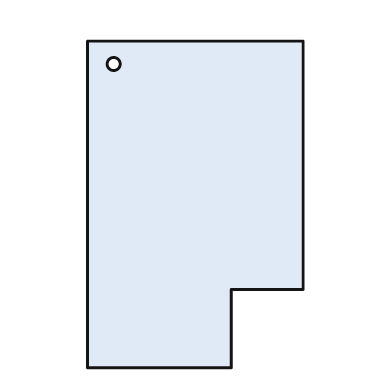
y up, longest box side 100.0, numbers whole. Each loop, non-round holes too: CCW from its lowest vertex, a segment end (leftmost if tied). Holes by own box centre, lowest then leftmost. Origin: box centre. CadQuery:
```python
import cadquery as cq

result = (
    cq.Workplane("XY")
    .moveTo(-33.0, -50.0)
    .lineTo(11.0, -50.0)
    .lineTo(11.0, -26.0)
    .lineTo(33.0, -26.0)
    .lineTo(33.0, 50.0)
    .lineTo(-33.0, 50.0)
    .close()
    .moveTo(-25.0, 43.0)
    .circle(2.0)
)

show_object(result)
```